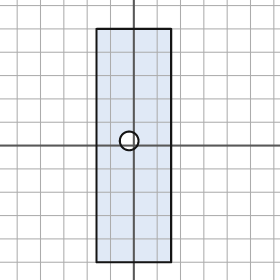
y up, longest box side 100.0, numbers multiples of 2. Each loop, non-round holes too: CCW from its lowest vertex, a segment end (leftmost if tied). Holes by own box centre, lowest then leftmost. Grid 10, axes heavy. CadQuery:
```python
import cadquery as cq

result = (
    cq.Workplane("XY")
    .moveTo(-16.0, -50.0)
    .lineTo(16.0, -50.0)
    .lineTo(16.0, 50.0)
    .lineTo(-16.0, 50.0)
    .close()
    .moveTo(-2.0, 2.0)
    .circle(4.0)
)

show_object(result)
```